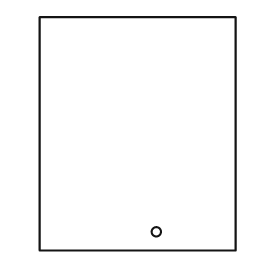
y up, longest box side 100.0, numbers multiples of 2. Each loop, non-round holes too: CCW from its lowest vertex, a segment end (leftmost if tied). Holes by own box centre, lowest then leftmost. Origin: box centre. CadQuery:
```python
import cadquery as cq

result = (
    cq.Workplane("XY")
    .moveTo(-42.0, -50.0)
    .lineTo(42.0, -50.0)
    .lineTo(42.0, 50.0)
    .lineTo(-42.0, 50.0)
    .close()
    .moveTo(8.0, -42.0)
    .circle(2.0)
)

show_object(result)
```